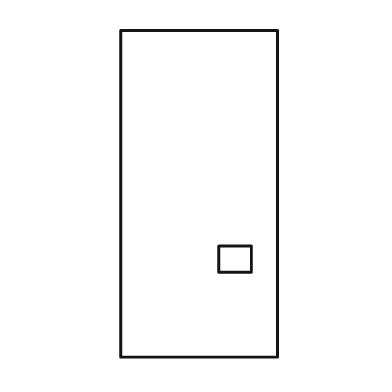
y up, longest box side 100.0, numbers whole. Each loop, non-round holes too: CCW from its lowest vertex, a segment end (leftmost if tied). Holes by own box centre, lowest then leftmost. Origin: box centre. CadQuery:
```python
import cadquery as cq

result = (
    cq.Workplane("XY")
    .moveTo(-24.0, -50.0)
    .lineTo(24.0, -50.0)
    .lineTo(24.0, 50.0)
    .lineTo(-24.0, 50.0)
    .close()
    .moveTo(6.0, -24.0)
    .lineTo(16.0, -24.0)
    .lineTo(16.0, -16.0)
    .lineTo(6.0, -16.0)
    .close()
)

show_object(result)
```